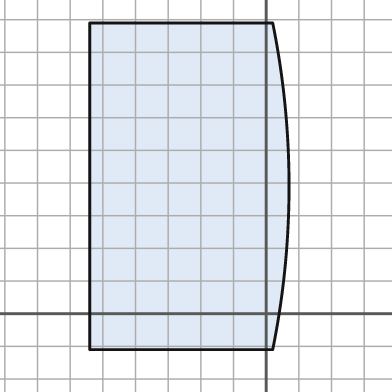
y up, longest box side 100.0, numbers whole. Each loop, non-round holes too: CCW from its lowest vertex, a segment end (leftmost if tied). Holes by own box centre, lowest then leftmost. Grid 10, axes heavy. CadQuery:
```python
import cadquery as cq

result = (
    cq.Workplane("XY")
    .moveTo(-54.0, -11.0)
    .lineTo(2.0, -11.0)
    .threePointArc((7.0, 39.0), (2.0, 89.0))
    .lineTo(-54.0, 89.0)
    .close()
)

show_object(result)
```